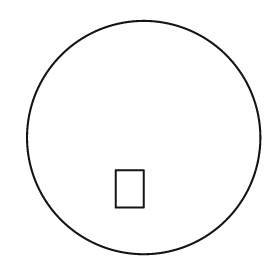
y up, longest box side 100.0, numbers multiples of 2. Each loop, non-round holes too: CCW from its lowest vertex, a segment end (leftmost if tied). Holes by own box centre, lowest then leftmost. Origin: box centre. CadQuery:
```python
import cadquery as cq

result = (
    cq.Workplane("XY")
    .moveTo(0.0, 0.0)
    .circle(50.0)
    .moveTo(-12.0, -30.0)
    .lineTo(0.0, -30.0)
    .lineTo(0.0, -14.0)
    .lineTo(-12.0, -14.0)
    .close()
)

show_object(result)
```